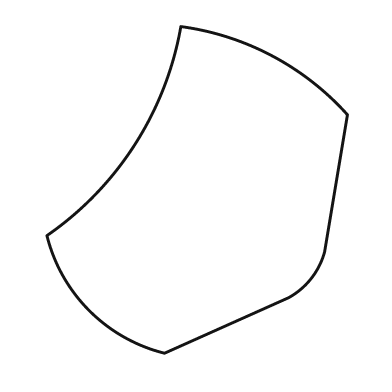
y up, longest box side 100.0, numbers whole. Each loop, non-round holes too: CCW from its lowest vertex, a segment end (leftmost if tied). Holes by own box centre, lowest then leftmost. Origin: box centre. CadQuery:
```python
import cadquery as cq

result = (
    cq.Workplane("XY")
    .moveTo(-10.0, -50.0)
    .lineTo(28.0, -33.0)
    .threePointArc((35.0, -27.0), (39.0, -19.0))
    .lineTo(46.0, 23.0)
    .threePointArc((23.0, 41.0), (-5.0, 50.0))
    .threePointArc((-19.0, 14.0), (-46.0, -14.0))
    .threePointArc((-33.0, -37.0), (-10.0, -50.0))
    .close()
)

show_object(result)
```